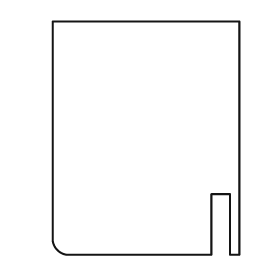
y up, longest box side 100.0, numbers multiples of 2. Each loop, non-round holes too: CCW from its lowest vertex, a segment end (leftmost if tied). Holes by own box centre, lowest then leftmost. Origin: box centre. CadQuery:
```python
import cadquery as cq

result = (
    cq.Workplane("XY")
    .moveTo(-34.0, -50.0)
    .lineTo(28.0, -50.0)
    .lineTo(28.0, -24.0)
    .lineTo(36.0, -24.0)
    .lineTo(36.0, -50.0)
    .lineTo(40.0, -50.0)
    .lineTo(40.0, 50.0)
    .lineTo(-40.0, 50.0)
    .lineTo(-40.0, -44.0)
    .threePointArc((-38.0, -48.0), (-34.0, -50.0))
    .close()
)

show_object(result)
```